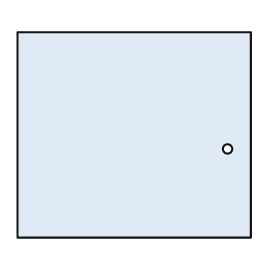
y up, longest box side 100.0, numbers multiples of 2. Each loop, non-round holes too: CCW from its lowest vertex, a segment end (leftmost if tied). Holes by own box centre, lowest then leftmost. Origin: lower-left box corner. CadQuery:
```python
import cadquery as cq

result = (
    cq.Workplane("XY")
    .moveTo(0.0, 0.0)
    .lineTo(100.0, 0.0)
    .lineTo(100.0, 88.0)
    .lineTo(0.0, 88.0)
    .close()
    .moveTo(90.0, 38.0)
    .circle(2.0)
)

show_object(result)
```